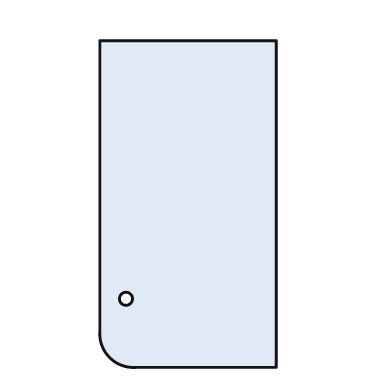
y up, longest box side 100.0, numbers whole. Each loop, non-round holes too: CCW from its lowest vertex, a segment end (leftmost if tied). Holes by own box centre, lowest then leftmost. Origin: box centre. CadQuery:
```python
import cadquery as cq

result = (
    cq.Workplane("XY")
    .moveTo(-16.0, -50.0)
    .lineTo(27.0, -50.0)
    .lineTo(27.0, 50.0)
    .lineTo(-27.0, 50.0)
    .lineTo(-27.0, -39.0)
    .threePointArc((-24.0, -47.0), (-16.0, -50.0))
    .close()
    .moveTo(-19.0, -29.0)
    .circle(2.0)
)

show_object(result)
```